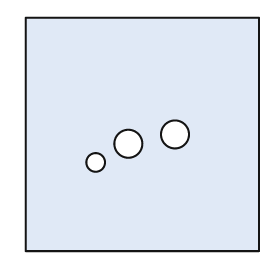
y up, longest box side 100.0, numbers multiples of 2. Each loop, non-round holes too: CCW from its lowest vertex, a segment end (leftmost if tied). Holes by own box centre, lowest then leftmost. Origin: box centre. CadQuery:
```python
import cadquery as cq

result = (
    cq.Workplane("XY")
    .moveTo(-50.0, -50.0)
    .lineTo(50.0, -50.0)
    .lineTo(50.0, 50.0)
    .lineTo(-50.0, 50.0)
    .close()
    .moveTo(-20.0, -12.0)
    .circle(4.0)
    .moveTo(-6.0, -4.0)
    .circle(6.0)
    .moveTo(14.0, 0.0)
    .circle(6.0)
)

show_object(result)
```